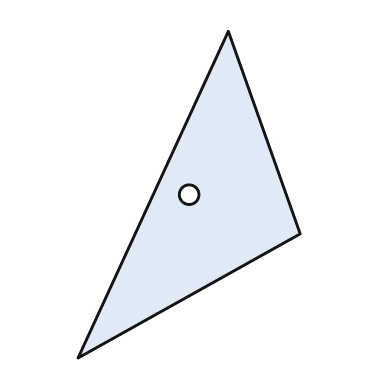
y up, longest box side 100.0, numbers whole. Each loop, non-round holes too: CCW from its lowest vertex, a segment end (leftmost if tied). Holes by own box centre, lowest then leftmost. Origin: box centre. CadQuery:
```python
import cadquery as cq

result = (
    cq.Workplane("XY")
    .moveTo(-34.0, -50.0)
    .lineTo(34.0, -12.0)
    .lineTo(12.0, 50.0)
    .close()
    .moveTo(0.0, 0.0)
    .circle(3.0)
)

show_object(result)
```